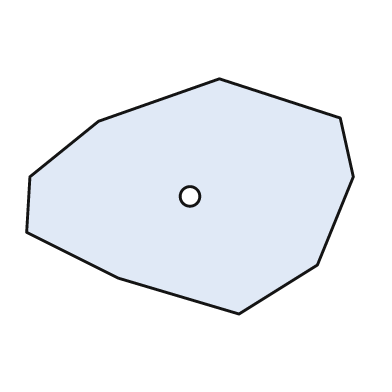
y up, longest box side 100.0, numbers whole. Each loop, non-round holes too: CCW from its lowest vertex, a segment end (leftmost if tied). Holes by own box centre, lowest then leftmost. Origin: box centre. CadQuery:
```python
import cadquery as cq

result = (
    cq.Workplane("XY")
    .moveTo(15.0, -36.0)
    .lineTo(39.0, -21.0)
    .lineTo(50.0, 6.0)
    .lineTo(46.0, 24.0)
    .lineTo(9.0, 36.0)
    .lineTo(-28.0, 23.0)
    .lineTo(-49.0, 6.0)
    .lineTo(-50.0, -11.0)
    .lineTo(-22.0, -25.0)
    .close()
    .moveTo(0.0, 0.0)
    .circle(3.0)
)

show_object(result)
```